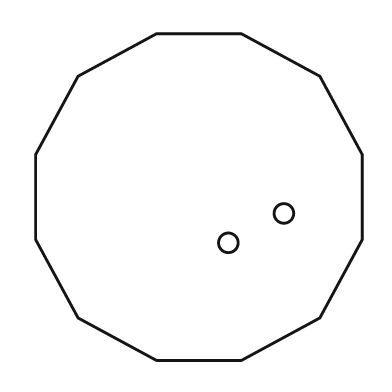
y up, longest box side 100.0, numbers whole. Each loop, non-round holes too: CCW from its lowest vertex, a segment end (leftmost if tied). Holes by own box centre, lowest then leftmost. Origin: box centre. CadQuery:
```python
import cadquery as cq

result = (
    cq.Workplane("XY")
    .moveTo(-13.0, -50.0)
    .lineTo(13.0, -50.0)
    .lineTo(37.0, -37.0)
    .lineTo(50.0, -13.0)
    .lineTo(50.0, 13.0)
    .lineTo(37.0, 37.0)
    .lineTo(13.0, 50.0)
    .lineTo(-13.0, 50.0)
    .lineTo(-37.0, 37.0)
    .lineTo(-50.0, 13.0)
    .lineTo(-50.0, -13.0)
    .lineTo(-37.0, -37.0)
    .close()
    .moveTo(9.0, -14.0)
    .circle(3.0)
    .moveTo(26.0, -5.0)
    .circle(3.0)
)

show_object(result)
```